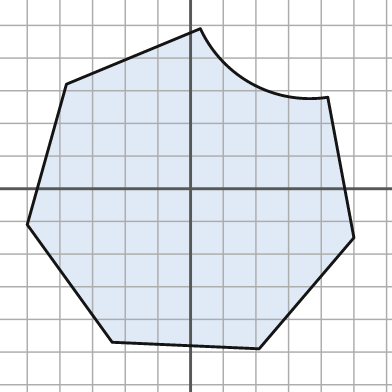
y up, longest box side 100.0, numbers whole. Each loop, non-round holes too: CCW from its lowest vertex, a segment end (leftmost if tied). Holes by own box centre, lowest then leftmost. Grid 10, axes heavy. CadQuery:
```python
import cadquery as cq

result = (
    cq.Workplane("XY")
    .moveTo(21.0, -49.0)
    .lineTo(50.0, -15.0)
    .lineTo(42.0, 28.0)
    .threePointArc((19.0, 32.0), (3.0, 49.0))
    .lineTo(-38.0, 32.0)
    .lineTo(-50.0, -11.0)
    .lineTo(-24.0, -47.0)
    .close()
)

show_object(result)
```